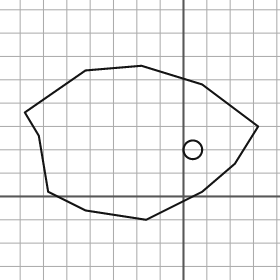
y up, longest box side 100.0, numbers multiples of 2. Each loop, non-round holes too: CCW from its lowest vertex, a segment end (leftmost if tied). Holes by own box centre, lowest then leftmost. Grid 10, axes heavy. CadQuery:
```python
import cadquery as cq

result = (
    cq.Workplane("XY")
    .moveTo(-16.0, -10.0)
    .lineTo(8.0, 2.0)
    .lineTo(22.0, 14.0)
    .lineTo(32.0, 30.0)
    .lineTo(8.0, 48.0)
    .lineTo(-18.0, 56.0)
    .lineTo(-42.0, 54.0)
    .lineTo(-68.0, 36.0)
    .lineTo(-62.0, 26.0)
    .lineTo(-58.0, 2.0)
    .lineTo(-42.0, -6.0)
    .close()
    .moveTo(4.0, 20.0)
    .circle(4.0)
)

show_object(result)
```